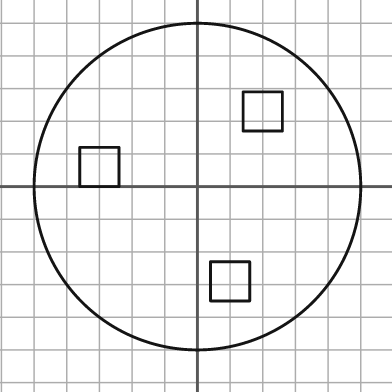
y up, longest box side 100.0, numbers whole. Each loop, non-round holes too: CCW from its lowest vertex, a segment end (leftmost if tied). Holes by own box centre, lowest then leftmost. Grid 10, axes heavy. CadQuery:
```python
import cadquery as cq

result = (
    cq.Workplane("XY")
    .moveTo(0.0, 0.0)
    .circle(50.0)
    .moveTo(4.0, -35.0)
    .lineTo(16.0, -35.0)
    .lineTo(16.0, -23.0)
    .lineTo(4.0, -23.0)
    .close()
    .moveTo(-36.0, 0.0)
    .lineTo(-24.0, 0.0)
    .lineTo(-24.0, 12.0)
    .lineTo(-36.0, 12.0)
    .close()
    .moveTo(14.0, 17.0)
    .lineTo(26.0, 17.0)
    .lineTo(26.0, 29.0)
    .lineTo(14.0, 29.0)
    .close()
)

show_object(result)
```